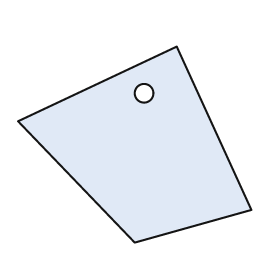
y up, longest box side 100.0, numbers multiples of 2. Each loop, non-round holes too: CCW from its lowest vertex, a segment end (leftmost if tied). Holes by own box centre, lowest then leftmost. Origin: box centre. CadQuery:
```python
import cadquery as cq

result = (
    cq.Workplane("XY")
    .moveTo(0.0, -42.0)
    .lineTo(50.0, -28.0)
    .lineTo(18.0, 42.0)
    .lineTo(-50.0, 10.0)
    .close()
    .moveTo(4.0, 22.0)
    .circle(4.0)
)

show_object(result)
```